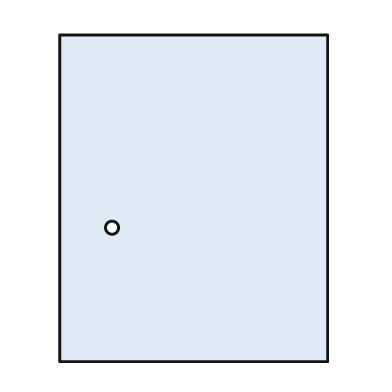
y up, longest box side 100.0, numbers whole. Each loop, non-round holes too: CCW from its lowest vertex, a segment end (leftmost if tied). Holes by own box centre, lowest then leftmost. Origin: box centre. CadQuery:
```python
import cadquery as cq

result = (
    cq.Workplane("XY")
    .moveTo(-41.0, -50.0)
    .lineTo(41.0, -50.0)
    .lineTo(41.0, 50.0)
    .lineTo(-41.0, 50.0)
    .close()
    .moveTo(-25.0, -9.0)
    .circle(2.0)
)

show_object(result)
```